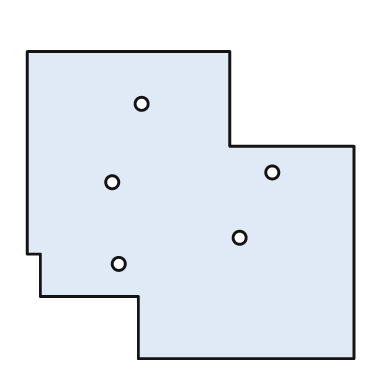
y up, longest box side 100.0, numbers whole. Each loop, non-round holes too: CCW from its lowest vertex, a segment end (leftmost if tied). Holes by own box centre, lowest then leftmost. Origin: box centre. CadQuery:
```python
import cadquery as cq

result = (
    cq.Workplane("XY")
    .moveTo(-16.0, -47.0)
    .lineTo(50.0, -47.0)
    .lineTo(50.0, 18.0)
    .lineTo(12.0, 18.0)
    .lineTo(12.0, 47.0)
    .lineTo(-50.0, 47.0)
    .lineTo(-50.0, -15.0)
    .lineTo(-46.0, -15.0)
    .lineTo(-46.0, -28.0)
    .lineTo(-16.0, -28.0)
    .close()
    .moveTo(-22.0, -18.0)
    .circle(2.0)
    .moveTo(15.0, -10.0)
    .circle(2.0)
    .moveTo(-24.0, 7.0)
    .circle(2.0)
    .moveTo(25.0, 10.0)
    .circle(2.0)
    .moveTo(-15.0, 31.0)
    .circle(2.0)
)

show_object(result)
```